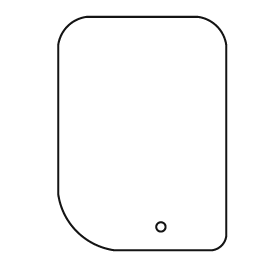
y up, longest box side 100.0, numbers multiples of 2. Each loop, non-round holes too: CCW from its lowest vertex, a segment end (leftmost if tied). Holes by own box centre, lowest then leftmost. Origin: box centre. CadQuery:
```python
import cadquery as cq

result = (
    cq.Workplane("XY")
    .moveTo(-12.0, -50.0)
    .lineTo(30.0, -50.0)
    .threePointArc((34.0, -48.0), (36.0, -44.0))
    .lineTo(36.0, 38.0)
    .threePointArc((32.0, 46.0), (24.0, 50.0))
    .lineTo(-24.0, 50.0)
    .threePointArc((-32.0, 46.0), (-36.0, 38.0))
    .lineTo(-36.0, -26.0)
    .threePointArc((-28.0, -42.0), (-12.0, -50.0))
    .close()
    .moveTo(8.0, -40.0)
    .circle(2.0)
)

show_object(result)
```